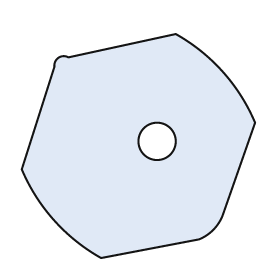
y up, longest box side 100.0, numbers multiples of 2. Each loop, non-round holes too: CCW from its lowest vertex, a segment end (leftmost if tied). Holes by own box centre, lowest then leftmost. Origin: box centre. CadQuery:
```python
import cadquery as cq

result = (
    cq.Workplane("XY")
    .moveTo(-16.0, -48.0)
    .lineTo(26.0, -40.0)
    .threePointArc((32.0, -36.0), (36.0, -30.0))
    .lineTo(50.0, 10.0)
    .threePointArc((36.0, 32.0), (16.0, 48.0))
    .lineTo(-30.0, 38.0)
    .threePointArc((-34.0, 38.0), (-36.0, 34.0))
    .lineTo(-50.0, -10.0)
    .threePointArc((-36.0, -32.0), (-16.0, -48.0))
    .close()
    .moveTo(8.0, 2.0)
    .circle(8.0)
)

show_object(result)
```